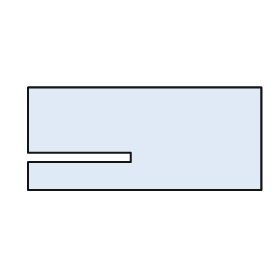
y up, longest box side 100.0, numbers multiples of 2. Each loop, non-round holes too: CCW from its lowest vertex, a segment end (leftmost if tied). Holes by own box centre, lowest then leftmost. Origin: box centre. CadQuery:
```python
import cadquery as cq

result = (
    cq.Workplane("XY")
    .moveTo(-50.0, -22.0)
    .lineTo(50.0, -22.0)
    .lineTo(50.0, 22.0)
    .lineTo(-50.0, 22.0)
    .lineTo(-50.0, -6.0)
    .lineTo(-6.0, -6.0)
    .lineTo(-6.0, -10.0)
    .lineTo(-50.0, -10.0)
    .close()
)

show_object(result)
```